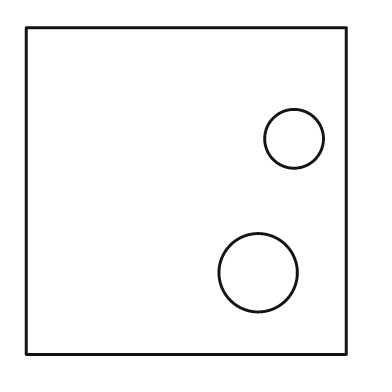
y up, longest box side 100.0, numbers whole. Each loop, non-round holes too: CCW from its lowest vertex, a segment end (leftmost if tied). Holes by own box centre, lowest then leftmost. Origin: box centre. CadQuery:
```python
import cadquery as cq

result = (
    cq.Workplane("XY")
    .moveTo(-49.0, -50.0)
    .lineTo(49.0, -50.0)
    .lineTo(49.0, 50.0)
    .lineTo(-49.0, 50.0)
    .close()
    .moveTo(22.0, -25.0)
    .circle(12.0)
    .moveTo(33.0, 16.0)
    .circle(9.0)
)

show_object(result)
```